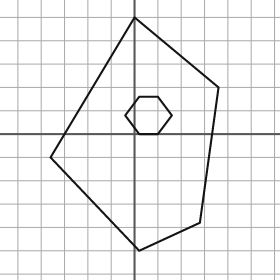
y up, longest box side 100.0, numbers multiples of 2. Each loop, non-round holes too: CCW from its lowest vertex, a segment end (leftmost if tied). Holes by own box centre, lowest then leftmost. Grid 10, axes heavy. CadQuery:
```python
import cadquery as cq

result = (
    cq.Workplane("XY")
    .moveTo(2.0, -50.0)
    .lineTo(28.0, -38.0)
    .lineTo(36.0, 20.0)
    .lineTo(0.0, 50.0)
    .lineTo(-36.0, -10.0)
    .close()
    .moveTo(2.0, 0.0)
    .lineTo(10.0, 0.0)
    .lineTo(16.0, 8.0)
    .lineTo(10.0, 16.0)
    .lineTo(2.0, 16.0)
    .lineTo(-4.0, 8.0)
    .close()
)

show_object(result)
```